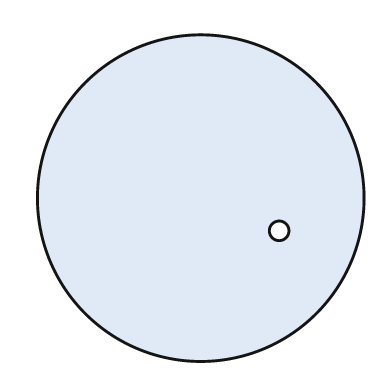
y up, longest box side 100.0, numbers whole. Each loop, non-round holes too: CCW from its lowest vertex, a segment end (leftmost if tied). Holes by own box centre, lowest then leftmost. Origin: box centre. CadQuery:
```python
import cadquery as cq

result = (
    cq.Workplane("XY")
    .moveTo(0.0, 0.0)
    .circle(50.0)
    .moveTo(24.0, -10.0)
    .circle(3.0)
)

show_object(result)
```